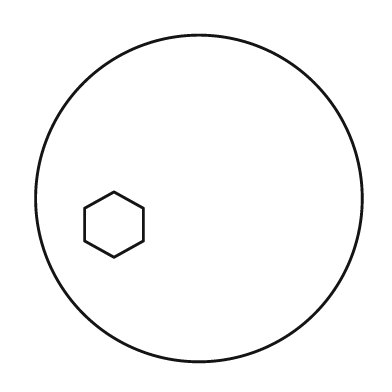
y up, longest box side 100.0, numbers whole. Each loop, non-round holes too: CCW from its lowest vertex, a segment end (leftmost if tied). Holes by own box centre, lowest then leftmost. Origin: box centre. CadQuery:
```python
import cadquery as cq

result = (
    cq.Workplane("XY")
    .moveTo(0.0, 0.0)
    .circle(50.0)
    .moveTo(-26.0, -18.0)
    .lineTo(-17.0, -13.0)
    .lineTo(-17.0, -3.0)
    .lineTo(-26.0, 2.0)
    .lineTo(-35.0, -3.0)
    .lineTo(-35.0, -13.0)
    .close()
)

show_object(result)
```